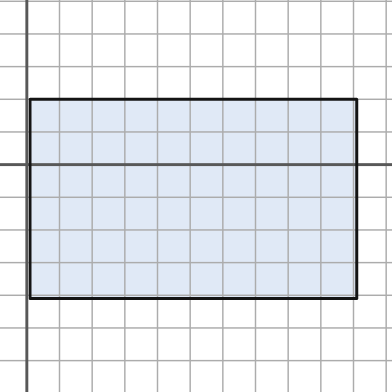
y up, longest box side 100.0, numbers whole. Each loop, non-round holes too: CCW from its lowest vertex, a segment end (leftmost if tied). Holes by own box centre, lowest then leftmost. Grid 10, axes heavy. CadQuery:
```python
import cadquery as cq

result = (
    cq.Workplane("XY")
    .moveTo(1.0, -41.0)
    .lineTo(101.0, -41.0)
    .lineTo(101.0, 20.0)
    .lineTo(1.0, 20.0)
    .close()
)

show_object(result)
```